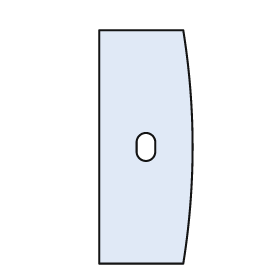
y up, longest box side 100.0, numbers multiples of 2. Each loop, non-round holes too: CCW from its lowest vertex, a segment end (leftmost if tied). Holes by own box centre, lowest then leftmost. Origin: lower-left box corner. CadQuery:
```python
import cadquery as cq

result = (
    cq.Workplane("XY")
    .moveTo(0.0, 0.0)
    .lineTo(36.0, 0.0)
    .threePointArc((40.0, 50.0), (36.0, 100.0))
    .lineTo(0.0, 100.0)
    .close()
    .moveTo(16.0, 48.0)
    .threePointArc((20.0, 44.0), (24.0, 48.0))
    .lineTo(24.0, 52.0)
    .threePointArc((20.0, 56.0), (16.0, 52.0))
    .close()
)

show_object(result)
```